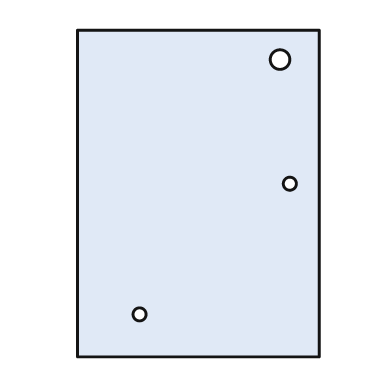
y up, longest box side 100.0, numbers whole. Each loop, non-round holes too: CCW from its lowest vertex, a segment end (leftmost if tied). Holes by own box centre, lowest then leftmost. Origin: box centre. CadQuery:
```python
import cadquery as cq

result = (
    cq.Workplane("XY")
    .moveTo(-37.0, -50.0)
    .lineTo(37.0, -50.0)
    .lineTo(37.0, 50.0)
    .lineTo(-37.0, 50.0)
    .close()
    .moveTo(-18.0, -37.0)
    .circle(2.0)
    .moveTo(28.0, 3.0)
    .circle(2.0)
    .moveTo(25.0, 41.0)
    .circle(3.0)
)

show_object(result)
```